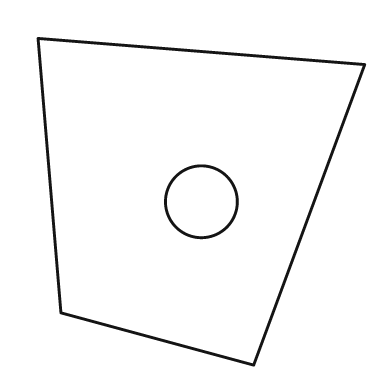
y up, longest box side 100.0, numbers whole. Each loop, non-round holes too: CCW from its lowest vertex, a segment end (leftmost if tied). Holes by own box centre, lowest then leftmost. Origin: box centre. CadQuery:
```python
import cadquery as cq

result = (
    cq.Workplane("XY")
    .moveTo(16.0, -50.0)
    .lineTo(50.0, 42.0)
    .lineTo(-50.0, 50.0)
    .lineTo(-43.0, -34.0)
    .close()
    .moveTo(0.0, 0.0)
    .circle(11.0)
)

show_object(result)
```